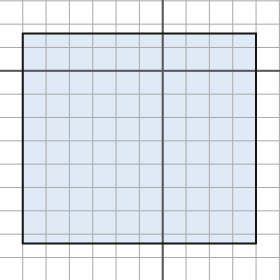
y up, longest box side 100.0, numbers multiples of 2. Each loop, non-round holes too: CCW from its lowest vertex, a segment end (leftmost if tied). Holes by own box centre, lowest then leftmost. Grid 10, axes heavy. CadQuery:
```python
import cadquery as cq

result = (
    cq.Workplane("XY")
    .moveTo(-60.0, -74.0)
    .lineTo(40.0, -74.0)
    .lineTo(40.0, 16.0)
    .lineTo(-60.0, 16.0)
    .close()
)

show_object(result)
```